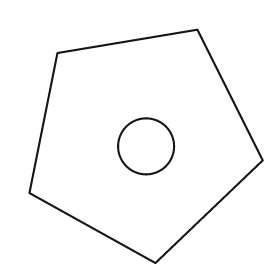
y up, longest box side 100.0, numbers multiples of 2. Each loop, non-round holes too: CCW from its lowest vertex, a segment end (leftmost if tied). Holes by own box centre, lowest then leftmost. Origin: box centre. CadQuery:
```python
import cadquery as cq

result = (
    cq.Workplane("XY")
    .moveTo(4.0, -50.0)
    .lineTo(50.0, -6.0)
    .lineTo(22.0, 50.0)
    .lineTo(-38.0, 40.0)
    .lineTo(-50.0, -20.0)
    .close()
    .moveTo(0.0, 0.0)
    .circle(12.0)
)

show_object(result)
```